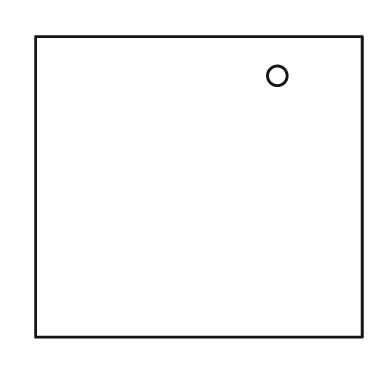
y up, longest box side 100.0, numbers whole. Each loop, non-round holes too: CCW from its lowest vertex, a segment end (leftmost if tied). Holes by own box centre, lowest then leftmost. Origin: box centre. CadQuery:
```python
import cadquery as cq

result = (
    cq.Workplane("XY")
    .moveTo(-50.0, -46.0)
    .lineTo(50.0, -46.0)
    .lineTo(50.0, 46.0)
    .lineTo(-50.0, 46.0)
    .close()
    .moveTo(24.0, 34.0)
    .circle(3.0)
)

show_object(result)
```